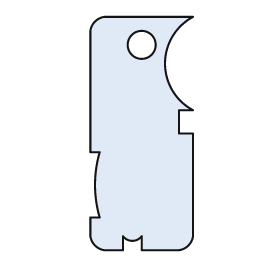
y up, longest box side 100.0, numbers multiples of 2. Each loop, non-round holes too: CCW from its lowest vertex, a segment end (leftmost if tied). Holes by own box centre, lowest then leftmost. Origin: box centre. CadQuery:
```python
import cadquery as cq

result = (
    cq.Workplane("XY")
    .moveTo(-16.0, -50.0)
    .lineTo(-8.0, -50.0)
    .lineTo(-8.0, -44.0)
    .threePointArc((-4.0, -46.0), (0.0, -44.0))
    .lineTo(0.0, -50.0)
    .lineTo(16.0, -50.0)
    .threePointArc((20.0, -48.0), (22.0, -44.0))
    .lineTo(22.0, 0.0)
    .lineTo(16.0, 0.0)
    .lineTo(16.0, 10.0)
    .lineTo(22.0, 10.0)
    .threePointArc((10.0, 30.0), (22.0, 50.0))
    .lineTo(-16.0, 50.0)
    .threePointArc((-20.0, 48.0), (-22.0, 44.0))
    .lineTo(-22.0, -8.0)
    .lineTo(-18.0, -8.0)
    .threePointArc((-20.0, -22.0), (-18.0, -36.0))
    .lineTo(-22.0, -36.0)
    .lineTo(-22.0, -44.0)
    .threePointArc((-20.0, -48.0), (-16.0, -50.0))
    .close()
    .moveTo(0.0, 38.0)
    .circle(6.0)
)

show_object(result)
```